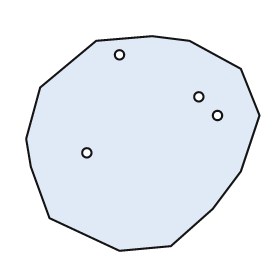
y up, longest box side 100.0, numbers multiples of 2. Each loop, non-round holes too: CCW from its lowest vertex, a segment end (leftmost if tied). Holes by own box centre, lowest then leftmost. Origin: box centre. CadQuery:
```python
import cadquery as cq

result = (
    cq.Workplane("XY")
    .moveTo(-10.0, -46.0)
    .lineTo(12.0, -44.0)
    .lineTo(30.0, -28.0)
    .lineTo(42.0, -12.0)
    .lineTo(50.0, 12.0)
    .lineTo(42.0, 32.0)
    .lineTo(20.0, 44.0)
    .lineTo(4.0, 46.0)
    .lineTo(-20.0, 44.0)
    .lineTo(-44.0, 24.0)
    .lineTo(-50.0, 2.0)
    .lineTo(-48.0, -10.0)
    .lineTo(-40.0, -32.0)
    .close()
    .moveTo(-24.0, -4.0)
    .circle(2.0)
    .moveTo(32.0, 12.0)
    .circle(2.0)
    .moveTo(24.0, 20.0)
    .circle(2.0)
    .moveTo(-10.0, 38.0)
    .circle(2.0)
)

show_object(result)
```